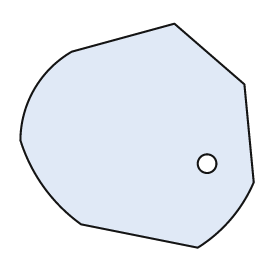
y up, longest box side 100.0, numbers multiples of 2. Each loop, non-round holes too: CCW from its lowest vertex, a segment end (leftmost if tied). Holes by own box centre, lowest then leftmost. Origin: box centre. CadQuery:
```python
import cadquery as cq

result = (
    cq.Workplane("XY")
    .moveTo(26.0, -48.0)
    .threePointArc((40.0, -36.0), (50.0, -20.0))
    .lineTo(46.0, 22.0)
    .lineTo(16.0, 48.0)
    .lineTo(-28.0, 36.0)
    .threePointArc((-44.0, 20.0), (-50.0, -2.0))
    .threePointArc((-40.0, -22.0), (-24.0, -38.0))
    .close()
    .moveTo(30.0, -12.0)
    .circle(4.0)
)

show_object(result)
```